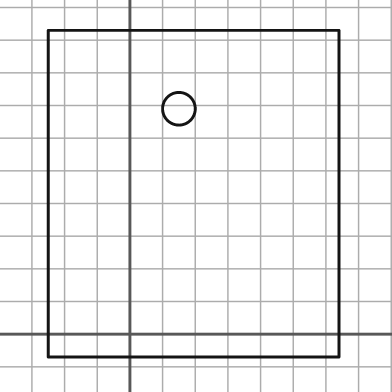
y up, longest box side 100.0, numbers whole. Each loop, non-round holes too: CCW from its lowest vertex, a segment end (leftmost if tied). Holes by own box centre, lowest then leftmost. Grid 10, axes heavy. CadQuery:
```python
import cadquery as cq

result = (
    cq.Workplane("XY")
    .moveTo(-25.0, -7.0)
    .lineTo(64.0, -7.0)
    .lineTo(64.0, 93.0)
    .lineTo(-25.0, 93.0)
    .close()
    .moveTo(15.0, 69.0)
    .circle(5.0)
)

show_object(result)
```